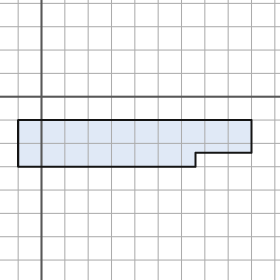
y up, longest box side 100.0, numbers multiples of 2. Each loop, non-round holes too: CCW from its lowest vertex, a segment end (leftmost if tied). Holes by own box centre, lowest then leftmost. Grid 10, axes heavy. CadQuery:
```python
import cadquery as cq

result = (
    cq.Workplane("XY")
    .moveTo(-10.0, -30.0)
    .lineTo(66.0, -30.0)
    .lineTo(66.0, -24.0)
    .lineTo(90.0, -24.0)
    .lineTo(90.0, -10.0)
    .lineTo(-10.0, -10.0)
    .close()
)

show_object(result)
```